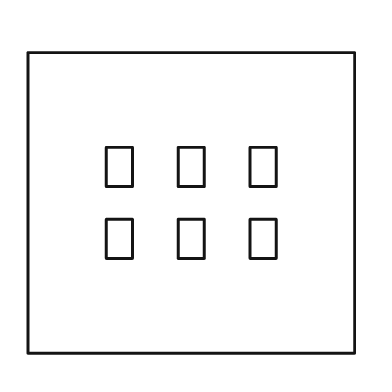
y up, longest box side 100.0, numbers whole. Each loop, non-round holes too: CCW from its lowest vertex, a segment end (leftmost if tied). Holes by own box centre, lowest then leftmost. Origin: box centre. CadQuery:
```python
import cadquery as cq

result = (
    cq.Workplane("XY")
    .moveTo(-50.0, -46.0)
    .lineTo(50.0, -46.0)
    .lineTo(50.0, 46.0)
    .lineTo(-50.0, 46.0)
    .close()
    .moveTo(-26.0, -17.0)
    .lineTo(-18.0, -17.0)
    .lineTo(-18.0, -5.0)
    .lineTo(-26.0, -5.0)
    .close()
    .moveTo(-4.0, -17.0)
    .lineTo(4.0, -17.0)
    .lineTo(4.0, -5.0)
    .lineTo(-4.0, -5.0)
    .close()
    .moveTo(18.0, -17.0)
    .lineTo(26.0, -17.0)
    .lineTo(26.0, -5.0)
    .lineTo(18.0, -5.0)
    .close()
    .moveTo(-26.0, 5.0)
    .lineTo(-18.0, 5.0)
    .lineTo(-18.0, 17.0)
    .lineTo(-26.0, 17.0)
    .close()
    .moveTo(-4.0, 5.0)
    .lineTo(4.0, 5.0)
    .lineTo(4.0, 17.0)
    .lineTo(-4.0, 17.0)
    .close()
    .moveTo(18.0, 5.0)
    .lineTo(26.0, 5.0)
    .lineTo(26.0, 17.0)
    .lineTo(18.0, 17.0)
    .close()
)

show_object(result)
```